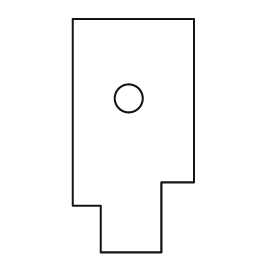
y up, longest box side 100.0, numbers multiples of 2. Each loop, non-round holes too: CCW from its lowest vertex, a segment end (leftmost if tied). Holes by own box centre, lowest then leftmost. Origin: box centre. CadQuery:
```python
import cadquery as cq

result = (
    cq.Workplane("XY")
    .moveTo(-14.0, -50.0)
    .lineTo(12.0, -50.0)
    .lineTo(12.0, -20.0)
    .lineTo(26.0, -20.0)
    .lineTo(26.0, 50.0)
    .lineTo(-26.0, 50.0)
    .lineTo(-26.0, -30.0)
    .lineTo(-14.0, -30.0)
    .close()
    .moveTo(-2.0, 16.0)
    .circle(6.0)
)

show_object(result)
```